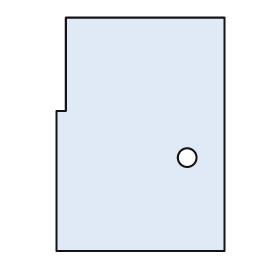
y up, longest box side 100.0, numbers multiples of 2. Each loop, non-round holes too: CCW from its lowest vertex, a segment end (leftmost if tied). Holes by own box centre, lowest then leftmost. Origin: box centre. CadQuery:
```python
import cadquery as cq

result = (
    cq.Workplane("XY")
    .moveTo(-36.0, -50.0)
    .lineTo(36.0, -50.0)
    .lineTo(36.0, 50.0)
    .lineTo(-32.0, 50.0)
    .lineTo(-32.0, 10.0)
    .lineTo(-36.0, 10.0)
    .close()
    .moveTo(20.0, -10.0)
    .circle(4.0)
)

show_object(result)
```